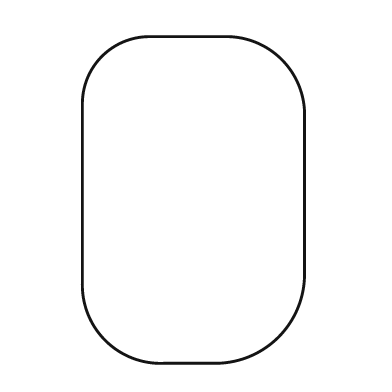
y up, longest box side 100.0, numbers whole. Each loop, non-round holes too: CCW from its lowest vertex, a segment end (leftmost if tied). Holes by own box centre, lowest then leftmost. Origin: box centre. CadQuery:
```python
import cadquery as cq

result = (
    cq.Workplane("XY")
    .moveTo(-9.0, -50.0)
    .lineTo(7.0, -50.0)
    .threePointArc((26.0, -42.0), (34.0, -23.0))
    .lineTo(34.0, 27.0)
    .threePointArc((27.0, 43.0), (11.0, 50.0))
    .lineTo(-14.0, 50.0)
    .threePointArc((-28.0, 44.0), (-34.0, 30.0))
    .lineTo(-34.0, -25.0)
    .threePointArc((-27.0, -43.0), (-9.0, -50.0))
    .close()
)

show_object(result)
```